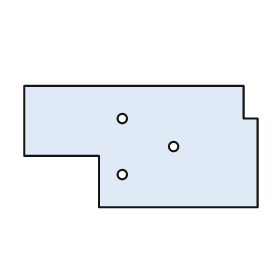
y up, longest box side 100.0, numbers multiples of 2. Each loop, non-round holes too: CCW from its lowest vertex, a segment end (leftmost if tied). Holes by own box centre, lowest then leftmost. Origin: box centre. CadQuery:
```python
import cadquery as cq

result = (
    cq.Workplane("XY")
    .moveTo(-18.0, -26.0)
    .lineTo(50.0, -26.0)
    .lineTo(50.0, 12.0)
    .lineTo(44.0, 12.0)
    .lineTo(44.0, 26.0)
    .lineTo(-50.0, 26.0)
    .lineTo(-50.0, -4.0)
    .lineTo(-18.0, -4.0)
    .close()
    .moveTo(-8.0, -12.0)
    .circle(2.0)
    .moveTo(14.0, 0.0)
    .circle(2.0)
    .moveTo(-8.0, 12.0)
    .circle(2.0)
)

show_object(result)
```